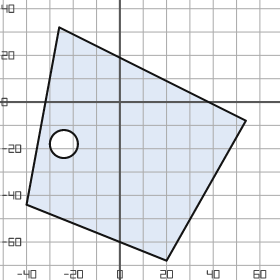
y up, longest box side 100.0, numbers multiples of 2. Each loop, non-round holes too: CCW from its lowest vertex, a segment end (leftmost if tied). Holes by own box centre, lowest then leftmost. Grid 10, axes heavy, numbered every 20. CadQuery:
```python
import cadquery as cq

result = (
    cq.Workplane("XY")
    .moveTo(20.0, -68.0)
    .lineTo(54.0, -8.0)
    .lineTo(-26.0, 32.0)
    .lineTo(-40.0, -44.0)
    .close()
    .moveTo(-24.0, -18.0)
    .circle(6.0)
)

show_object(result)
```